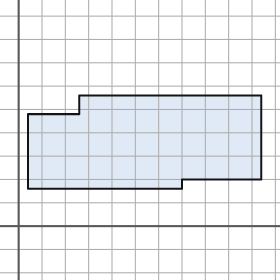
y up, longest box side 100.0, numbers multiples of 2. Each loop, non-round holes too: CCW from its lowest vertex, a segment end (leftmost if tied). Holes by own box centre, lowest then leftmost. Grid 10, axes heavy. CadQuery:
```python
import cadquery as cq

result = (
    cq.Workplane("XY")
    .moveTo(4.0, 16.0)
    .lineTo(70.0, 16.0)
    .lineTo(70.0, 20.0)
    .lineTo(104.0, 20.0)
    .lineTo(104.0, 56.0)
    .lineTo(26.0, 56.0)
    .lineTo(26.0, 48.0)
    .lineTo(4.0, 48.0)
    .close()
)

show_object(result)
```